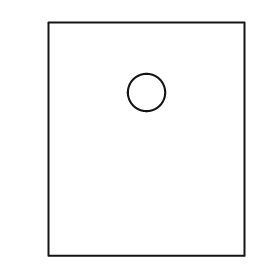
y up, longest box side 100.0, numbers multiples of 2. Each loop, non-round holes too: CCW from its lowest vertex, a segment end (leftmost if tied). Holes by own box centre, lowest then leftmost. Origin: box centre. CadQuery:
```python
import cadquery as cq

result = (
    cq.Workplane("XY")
    .moveTo(-42.0, -50.0)
    .lineTo(42.0, -50.0)
    .lineTo(42.0, 50.0)
    .lineTo(-42.0, 50.0)
    .close()
    .moveTo(0.0, 20.0)
    .circle(8.0)
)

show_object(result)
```